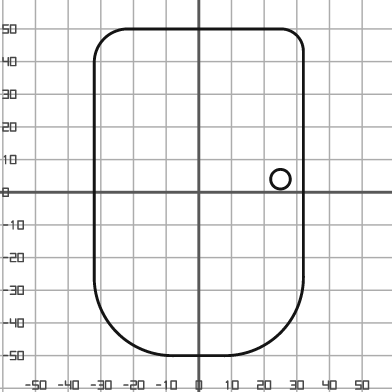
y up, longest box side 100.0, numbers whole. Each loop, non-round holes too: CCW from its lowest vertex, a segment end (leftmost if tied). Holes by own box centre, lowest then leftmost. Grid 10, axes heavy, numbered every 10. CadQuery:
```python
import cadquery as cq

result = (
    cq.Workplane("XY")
    .moveTo(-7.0, -50.0)
    .lineTo(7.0, -50.0)
    .threePointArc((25.0, -43.0), (32.0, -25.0))
    .lineTo(32.0, 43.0)
    .threePointArc((30.0, 48.0), (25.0, 50.0))
    .lineTo(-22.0, 50.0)
    .threePointArc((-29.0, 47.0), (-32.0, 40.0))
    .lineTo(-32.0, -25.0)
    .threePointArc((-25.0, -43.0), (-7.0, -50.0))
    .close()
    .moveTo(25.0, 4.0)
    .circle(3.0)
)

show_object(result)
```